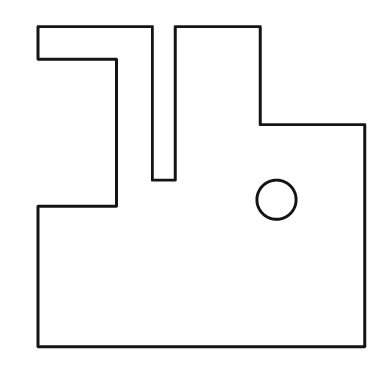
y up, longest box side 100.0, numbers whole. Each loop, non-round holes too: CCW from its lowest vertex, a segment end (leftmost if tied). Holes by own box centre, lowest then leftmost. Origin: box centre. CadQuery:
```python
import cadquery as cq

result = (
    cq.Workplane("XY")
    .moveTo(-50.0, -49.0)
    .lineTo(50.0, -49.0)
    .lineTo(50.0, 19.0)
    .lineTo(18.0, 19.0)
    .lineTo(18.0, 49.0)
    .lineTo(-8.0, 49.0)
    .lineTo(-8.0, 2.0)
    .lineTo(-15.0, 2.0)
    .lineTo(-15.0, 49.0)
    .lineTo(-50.0, 49.0)
    .lineTo(-50.0, 39.0)
    .lineTo(-26.0, 39.0)
    .lineTo(-26.0, -6.0)
    .lineTo(-50.0, -6.0)
    .close()
    .moveTo(23.0, -4.0)
    .circle(6.0)
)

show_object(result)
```